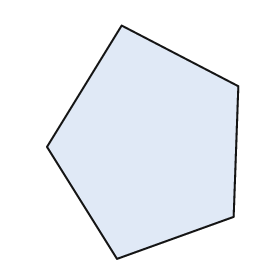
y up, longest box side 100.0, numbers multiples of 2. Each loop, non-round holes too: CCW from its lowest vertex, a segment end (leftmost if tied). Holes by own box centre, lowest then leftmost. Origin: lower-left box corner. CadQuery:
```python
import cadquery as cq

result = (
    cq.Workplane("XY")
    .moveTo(30.0, 0.0)
    .lineTo(80.0, 18.0)
    .lineTo(82.0, 74.0)
    .lineTo(32.0, 100.0)
    .lineTo(0.0, 48.0)
    .close()
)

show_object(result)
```